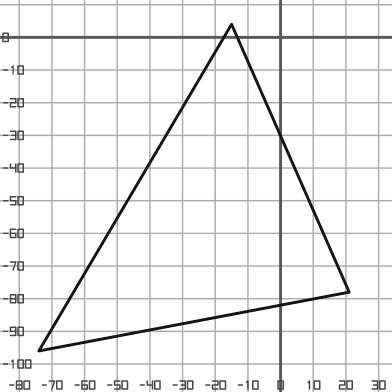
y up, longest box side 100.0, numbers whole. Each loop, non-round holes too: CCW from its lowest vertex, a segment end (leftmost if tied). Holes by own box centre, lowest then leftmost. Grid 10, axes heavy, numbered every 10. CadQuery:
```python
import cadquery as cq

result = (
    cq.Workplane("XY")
    .moveTo(-74.0, -96.0)
    .lineTo(21.0, -78.0)
    .lineTo(-15.0, 4.0)
    .close()
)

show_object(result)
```